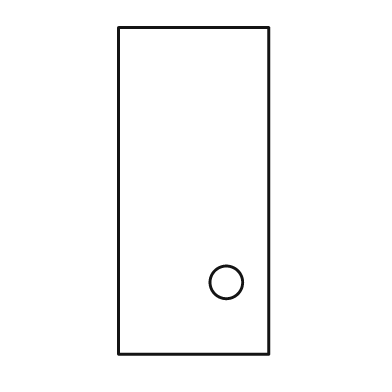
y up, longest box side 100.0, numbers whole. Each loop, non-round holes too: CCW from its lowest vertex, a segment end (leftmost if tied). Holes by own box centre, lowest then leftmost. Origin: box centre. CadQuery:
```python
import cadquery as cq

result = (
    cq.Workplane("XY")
    .moveTo(-23.0, -50.0)
    .lineTo(23.0, -50.0)
    .lineTo(23.0, 50.0)
    .lineTo(-23.0, 50.0)
    .close()
    .moveTo(10.0, -28.0)
    .circle(5.0)
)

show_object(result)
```